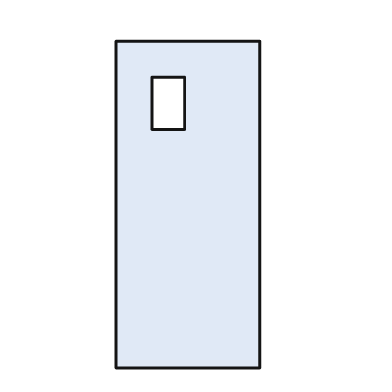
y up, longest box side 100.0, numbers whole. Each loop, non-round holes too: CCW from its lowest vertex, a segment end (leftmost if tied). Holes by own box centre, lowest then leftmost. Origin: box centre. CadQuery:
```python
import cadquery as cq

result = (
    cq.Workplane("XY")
    .moveTo(-22.0, -50.0)
    .lineTo(22.0, -50.0)
    .lineTo(22.0, 50.0)
    .lineTo(-22.0, 50.0)
    .close()
    .moveTo(-11.0, 23.0)
    .lineTo(-1.0, 23.0)
    .lineTo(-1.0, 39.0)
    .lineTo(-11.0, 39.0)
    .close()
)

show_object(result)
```